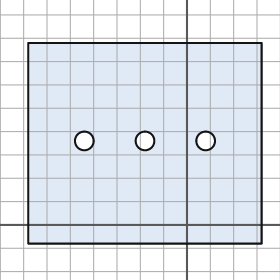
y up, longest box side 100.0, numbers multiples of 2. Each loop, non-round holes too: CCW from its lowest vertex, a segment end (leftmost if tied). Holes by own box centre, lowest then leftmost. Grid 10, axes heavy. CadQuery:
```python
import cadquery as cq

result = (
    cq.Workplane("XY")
    .moveTo(-68.0, -8.0)
    .lineTo(32.0, -8.0)
    .lineTo(32.0, 78.0)
    .lineTo(-68.0, 78.0)
    .close()
    .moveTo(-44.0, 36.0)
    .circle(4.0)
    .moveTo(-18.0, 36.0)
    .circle(4.0)
    .moveTo(8.0, 36.0)
    .circle(4.0)
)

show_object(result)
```